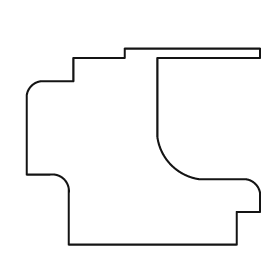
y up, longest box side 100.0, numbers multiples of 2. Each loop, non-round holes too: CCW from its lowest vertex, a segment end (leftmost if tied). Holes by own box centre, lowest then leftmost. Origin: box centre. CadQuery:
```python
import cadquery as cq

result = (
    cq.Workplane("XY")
    .moveTo(-32.0, -42.0)
    .lineTo(40.0, -42.0)
    .lineTo(40.0, -28.0)
    .lineTo(50.0, -28.0)
    .lineTo(50.0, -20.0)
    .threePointArc((48.0, -16.0), (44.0, -14.0))
    .lineTo(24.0, -14.0)
    .threePointArc((12.0, -8.0), (6.0, 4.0))
    .lineTo(6.0, 38.0)
    .lineTo(50.0, 38.0)
    .lineTo(50.0, 42.0)
    .lineTo(-8.0, 42.0)
    .lineTo(-8.0, 38.0)
    .lineTo(-30.0, 38.0)
    .lineTo(-30.0, 28.0)
    .lineTo(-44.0, 28.0)
    .threePointArc((-48.0, 26.0), (-50.0, 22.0))
    .lineTo(-50.0, -12.0)
    .lineTo(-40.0, -12.0)
    .threePointArc((-34.0, -14.0), (-32.0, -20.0))
    .close()
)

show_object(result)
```